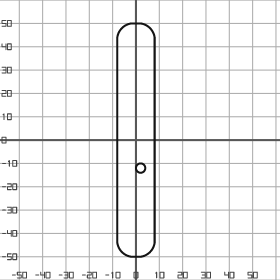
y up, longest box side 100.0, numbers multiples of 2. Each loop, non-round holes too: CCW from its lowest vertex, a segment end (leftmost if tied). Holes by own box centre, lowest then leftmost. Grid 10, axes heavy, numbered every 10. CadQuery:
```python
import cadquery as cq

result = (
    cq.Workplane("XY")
    .moveTo(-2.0, -50.0)
    .lineTo(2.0, -50.0)
    .threePointArc((6.0, -48.0), (8.0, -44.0))
    .lineTo(8.0, 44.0)
    .threePointArc((6.0, 48.0), (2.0, 50.0))
    .lineTo(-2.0, 50.0)
    .threePointArc((-6.0, 48.0), (-8.0, 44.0))
    .lineTo(-8.0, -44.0)
    .threePointArc((-6.0, -48.0), (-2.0, -50.0))
    .close()
    .moveTo(2.0, -12.0)
    .circle(2.0)
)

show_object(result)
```